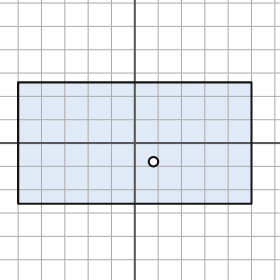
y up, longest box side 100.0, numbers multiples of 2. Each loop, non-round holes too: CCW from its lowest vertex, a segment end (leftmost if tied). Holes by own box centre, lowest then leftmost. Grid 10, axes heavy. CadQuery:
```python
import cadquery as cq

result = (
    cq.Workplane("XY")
    .moveTo(-50.0, -26.0)
    .lineTo(50.0, -26.0)
    .lineTo(50.0, 26.0)
    .lineTo(-50.0, 26.0)
    .close()
    .moveTo(8.0, -8.0)
    .circle(2.0)
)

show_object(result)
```